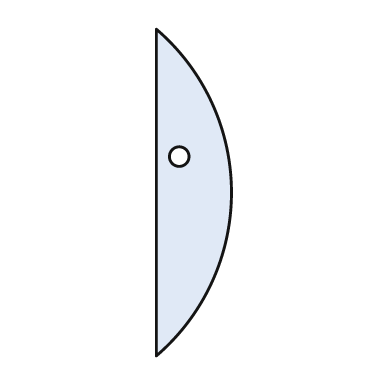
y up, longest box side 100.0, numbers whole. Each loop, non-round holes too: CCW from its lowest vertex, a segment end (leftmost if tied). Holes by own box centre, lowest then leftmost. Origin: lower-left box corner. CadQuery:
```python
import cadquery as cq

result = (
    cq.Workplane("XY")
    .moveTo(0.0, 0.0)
    .threePointArc((23.0, 50.0), (0.0, 100.0))
    .close()
    .moveTo(7.0, 61.0)
    .circle(3.0)
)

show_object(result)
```